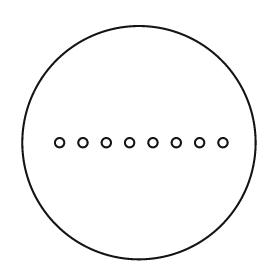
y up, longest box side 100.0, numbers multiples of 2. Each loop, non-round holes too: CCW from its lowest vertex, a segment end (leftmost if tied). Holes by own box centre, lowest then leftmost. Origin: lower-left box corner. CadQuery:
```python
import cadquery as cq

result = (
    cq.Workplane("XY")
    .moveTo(50.0, 50.0)
    .circle(50.0)
    .moveTo(16.0, 50.0)
    .circle(2.0)
    .moveTo(26.0, 50.0)
    .circle(2.0)
    .moveTo(36.0, 50.0)
    .circle(2.0)
    .moveTo(46.0, 50.0)
    .circle(2.0)
    .moveTo(56.0, 50.0)
    .circle(2.0)
    .moveTo(66.0, 50.0)
    .circle(2.0)
    .moveTo(76.0, 50.0)
    .circle(2.0)
    .moveTo(86.0, 50.0)
    .circle(2.0)
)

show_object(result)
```